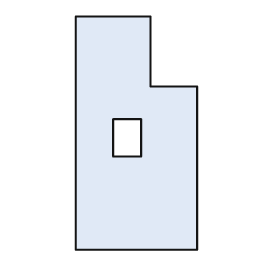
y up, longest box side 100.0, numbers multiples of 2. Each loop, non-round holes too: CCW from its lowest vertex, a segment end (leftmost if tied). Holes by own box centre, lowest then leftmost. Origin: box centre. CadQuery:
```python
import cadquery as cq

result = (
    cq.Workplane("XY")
    .moveTo(-26.0, -50.0)
    .lineTo(26.0, -50.0)
    .lineTo(26.0, 20.0)
    .lineTo(6.0, 20.0)
    .lineTo(6.0, 50.0)
    .lineTo(-26.0, 50.0)
    .close()
    .moveTo(-10.0, -10.0)
    .lineTo(2.0, -10.0)
    .lineTo(2.0, 6.0)
    .lineTo(-10.0, 6.0)
    .close()
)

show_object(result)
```